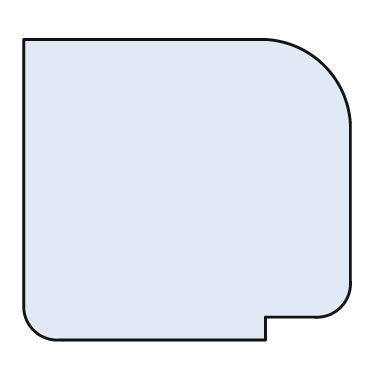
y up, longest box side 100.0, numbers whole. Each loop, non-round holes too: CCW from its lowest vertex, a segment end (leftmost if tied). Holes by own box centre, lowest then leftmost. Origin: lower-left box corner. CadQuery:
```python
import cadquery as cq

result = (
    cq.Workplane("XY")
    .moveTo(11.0, 0.0)
    .lineTo(74.0, 0.0)
    .lineTo(74.0, 7.0)
    .lineTo(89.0, 7.0)
    .threePointArc((97.0, 10.0), (100.0, 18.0))
    .lineTo(100.0, 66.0)
    .threePointArc((92.0, 84.0), (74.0, 92.0))
    .lineTo(0.0, 92.0)
    .lineTo(0.0, 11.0)
    .threePointArc((3.0, 3.0), (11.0, 0.0))
    .close()
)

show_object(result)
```